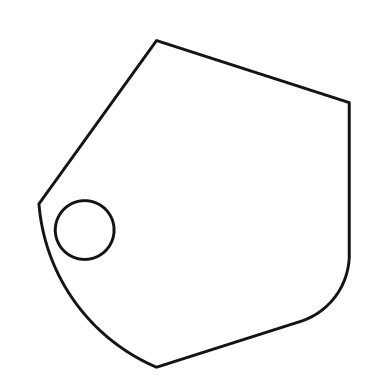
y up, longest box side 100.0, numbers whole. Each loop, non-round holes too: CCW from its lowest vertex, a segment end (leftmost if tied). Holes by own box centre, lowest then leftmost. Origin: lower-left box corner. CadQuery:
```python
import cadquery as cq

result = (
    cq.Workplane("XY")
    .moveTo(36.0, 0.0)
    .lineTo(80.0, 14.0)
    .threePointArc((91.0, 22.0), (95.0, 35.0))
    .lineTo(95.0, 81.0)
    .lineTo(36.0, 100.0)
    .lineTo(0.0, 50.0)
    .threePointArc((11.0, 20.0), (36.0, 0.0))
    .close()
    .moveTo(14.0, 42.0)
    .circle(9.0)
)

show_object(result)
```